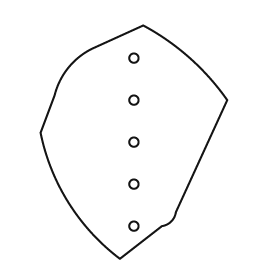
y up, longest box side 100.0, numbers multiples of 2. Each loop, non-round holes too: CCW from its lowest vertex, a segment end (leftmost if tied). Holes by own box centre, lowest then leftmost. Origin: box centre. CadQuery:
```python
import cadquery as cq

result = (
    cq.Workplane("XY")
    .moveTo(-6.0, -50.0)
    .lineTo(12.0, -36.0)
    .threePointArc((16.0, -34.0), (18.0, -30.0))
    .lineTo(40.0, 18.0)
    .threePointArc((24.0, 36.0), (4.0, 50.0))
    .lineTo(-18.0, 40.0)
    .threePointArc((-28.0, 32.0), (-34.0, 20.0))
    .lineTo(-40.0, 4.0)
    .threePointArc((-28.0, -26.0), (-6.0, -50.0))
    .close()
    .moveTo(0.0, -36.0)
    .circle(2.0)
    .moveTo(0.0, -18.0)
    .circle(2.0)
    .moveTo(0.0, 0.0)
    .circle(2.0)
    .moveTo(0.0, 18.0)
    .circle(2.0)
    .moveTo(0.0, 36.0)
    .circle(2.0)
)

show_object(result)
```